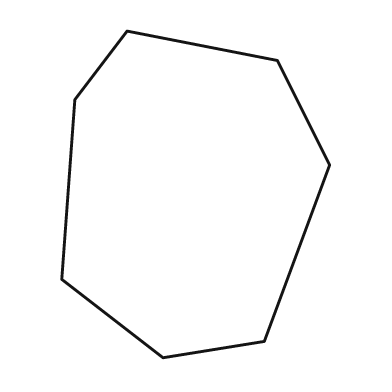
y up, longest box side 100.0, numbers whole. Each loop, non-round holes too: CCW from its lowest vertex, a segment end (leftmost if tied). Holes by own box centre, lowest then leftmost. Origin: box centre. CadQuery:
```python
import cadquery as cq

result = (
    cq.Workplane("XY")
    .moveTo(-10.0, -50.0)
    .lineTo(21.0, -45.0)
    .lineTo(41.0, 9.0)
    .lineTo(25.0, 41.0)
    .lineTo(-21.0, 50.0)
    .lineTo(-37.0, 29.0)
    .lineTo(-41.0, -26.0)
    .close()
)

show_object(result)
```